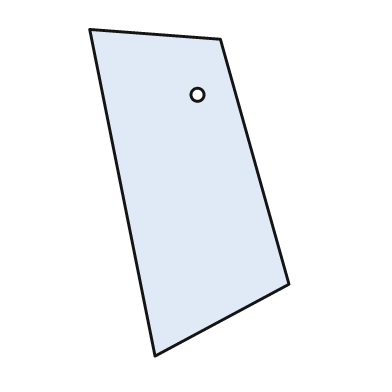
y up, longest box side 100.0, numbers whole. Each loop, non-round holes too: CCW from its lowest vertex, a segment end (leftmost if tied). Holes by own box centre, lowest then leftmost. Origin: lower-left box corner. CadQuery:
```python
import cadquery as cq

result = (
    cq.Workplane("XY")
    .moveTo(20.0, 0.0)
    .lineTo(61.0, 22.0)
    .lineTo(40.0, 97.0)
    .lineTo(0.0, 100.0)
    .close()
    .moveTo(33.0, 80.0)
    .circle(2.0)
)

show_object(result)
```